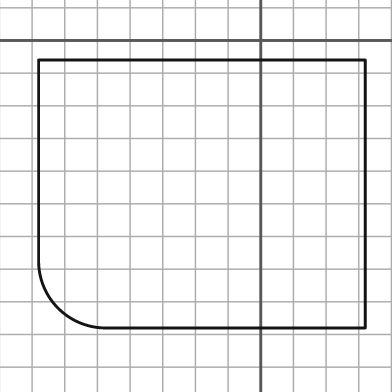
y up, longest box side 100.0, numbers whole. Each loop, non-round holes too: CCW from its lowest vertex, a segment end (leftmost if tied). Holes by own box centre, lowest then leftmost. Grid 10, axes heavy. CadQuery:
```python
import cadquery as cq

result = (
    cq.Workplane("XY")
    .moveTo(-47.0, -88.0)
    .lineTo(32.0, -88.0)
    .lineTo(32.0, -6.0)
    .lineTo(-68.0, -6.0)
    .lineTo(-68.0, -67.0)
    .threePointArc((-62.0, -82.0), (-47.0, -88.0))
    .close()
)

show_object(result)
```